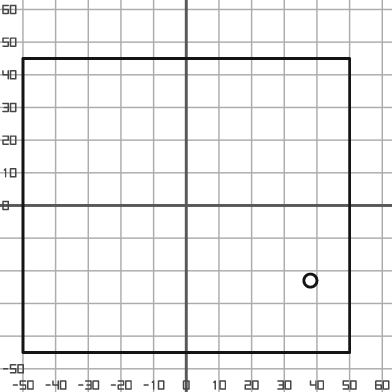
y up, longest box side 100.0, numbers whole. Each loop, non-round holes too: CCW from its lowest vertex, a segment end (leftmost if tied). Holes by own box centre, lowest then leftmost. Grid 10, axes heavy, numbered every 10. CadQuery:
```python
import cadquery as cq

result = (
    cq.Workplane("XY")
    .moveTo(-50.0, -45.0)
    .lineTo(50.0, -45.0)
    .lineTo(50.0, 45.0)
    .lineTo(-50.0, 45.0)
    .close()
    .moveTo(38.0, -23.0)
    .circle(2.0)
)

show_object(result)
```